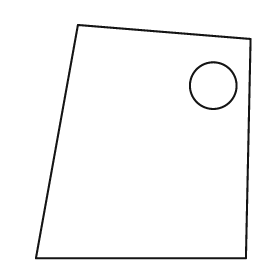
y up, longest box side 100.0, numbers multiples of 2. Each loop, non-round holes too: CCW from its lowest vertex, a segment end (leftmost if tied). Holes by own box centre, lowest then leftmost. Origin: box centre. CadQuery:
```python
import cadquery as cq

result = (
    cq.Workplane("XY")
    .moveTo(-46.0, -50.0)
    .lineTo(44.0, -50.0)
    .lineTo(46.0, 44.0)
    .lineTo(-28.0, 50.0)
    .close()
    .moveTo(30.0, 24.0)
    .circle(10.0)
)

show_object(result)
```